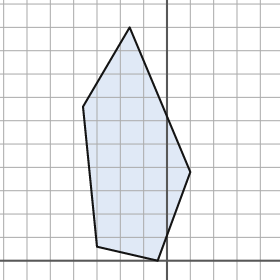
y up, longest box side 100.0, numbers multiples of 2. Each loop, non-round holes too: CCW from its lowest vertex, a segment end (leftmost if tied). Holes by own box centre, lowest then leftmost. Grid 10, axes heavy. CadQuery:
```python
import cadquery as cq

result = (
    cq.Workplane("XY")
    .moveTo(-4.0, 0.0)
    .lineTo(10.0, 38.0)
    .lineTo(-16.0, 100.0)
    .lineTo(-36.0, 66.0)
    .lineTo(-30.0, 6.0)
    .close()
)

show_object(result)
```